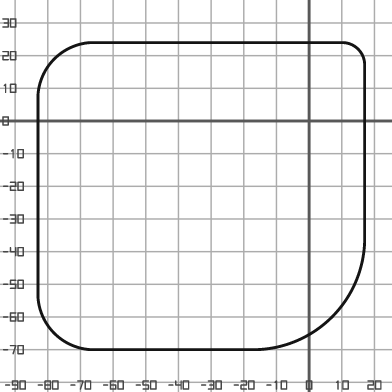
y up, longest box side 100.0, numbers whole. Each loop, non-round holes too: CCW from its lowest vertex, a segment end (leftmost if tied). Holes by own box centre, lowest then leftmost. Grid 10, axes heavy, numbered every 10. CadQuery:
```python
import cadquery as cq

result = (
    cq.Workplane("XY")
    .moveTo(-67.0, -70.0)
    .lineTo(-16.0, -70.0)
    .threePointArc((7.0, -60.0), (17.0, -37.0))
    .lineTo(17.0, 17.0)
    .threePointArc((15.0, 22.0), (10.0, 24.0))
    .lineTo(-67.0, 24.0)
    .threePointArc((-78.0, 19.0), (-83.0, 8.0))
    .lineTo(-83.0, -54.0)
    .threePointArc((-78.0, -65.0), (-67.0, -70.0))
    .close()
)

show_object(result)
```